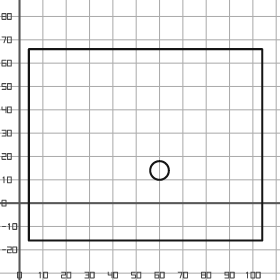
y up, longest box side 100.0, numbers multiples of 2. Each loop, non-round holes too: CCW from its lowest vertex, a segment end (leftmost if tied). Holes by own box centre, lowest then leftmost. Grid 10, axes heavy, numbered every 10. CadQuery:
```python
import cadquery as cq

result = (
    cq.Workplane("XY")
    .moveTo(4.0, -16.0)
    .lineTo(104.0, -16.0)
    .lineTo(104.0, 66.0)
    .lineTo(4.0, 66.0)
    .close()
    .moveTo(60.0, 14.0)
    .circle(4.0)
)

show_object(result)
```